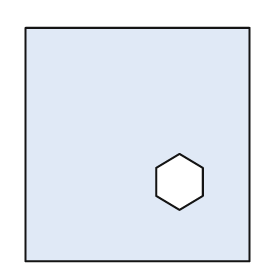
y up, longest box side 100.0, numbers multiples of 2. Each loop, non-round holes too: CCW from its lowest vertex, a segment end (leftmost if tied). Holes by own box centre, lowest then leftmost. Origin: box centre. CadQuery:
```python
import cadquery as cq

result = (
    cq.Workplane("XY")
    .moveTo(-48.0, -50.0)
    .lineTo(48.0, -50.0)
    .lineTo(48.0, 50.0)
    .lineTo(-48.0, 50.0)
    .close()
    .moveTo(18.0, -28.0)
    .lineTo(28.0, -22.0)
    .lineTo(28.0, -10.0)
    .lineTo(18.0, -4.0)
    .lineTo(8.0, -10.0)
    .lineTo(8.0, -22.0)
    .close()
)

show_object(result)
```